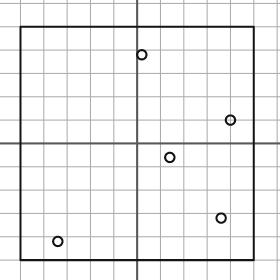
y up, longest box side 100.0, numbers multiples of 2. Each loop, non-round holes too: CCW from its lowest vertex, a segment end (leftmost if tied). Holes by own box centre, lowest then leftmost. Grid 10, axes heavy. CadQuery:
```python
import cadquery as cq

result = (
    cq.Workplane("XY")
    .moveTo(-50.0, -50.0)
    .lineTo(50.0, -50.0)
    .lineTo(50.0, 50.0)
    .lineTo(-50.0, 50.0)
    .close()
    .moveTo(-34.0, -42.0)
    .circle(2.0)
    .moveTo(36.0, -32.0)
    .circle(2.0)
    .moveTo(14.0, -6.0)
    .circle(2.0)
    .moveTo(40.0, 10.0)
    .circle(2.0)
    .moveTo(2.0, 38.0)
    .circle(2.0)
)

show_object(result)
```